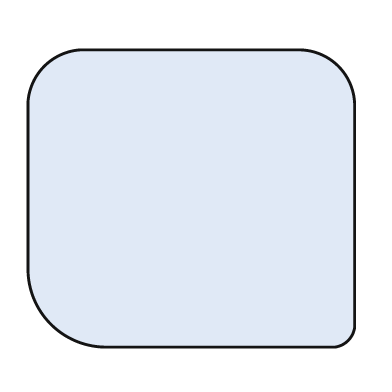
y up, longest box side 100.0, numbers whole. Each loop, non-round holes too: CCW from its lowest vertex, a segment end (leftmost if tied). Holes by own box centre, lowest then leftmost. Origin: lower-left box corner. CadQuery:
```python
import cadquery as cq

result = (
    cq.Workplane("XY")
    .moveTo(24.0, 0.0)
    .lineTo(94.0, 0.0)
    .threePointArc((98.0, 2.0), (100.0, 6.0))
    .lineTo(100.0, 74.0)
    .threePointArc((95.0, 86.0), (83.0, 91.0))
    .lineTo(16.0, 91.0)
    .threePointArc((5.0, 86.0), (0.0, 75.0))
    .lineTo(0.0, 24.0)
    .threePointArc((7.0, 7.0), (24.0, 0.0))
    .close()
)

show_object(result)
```